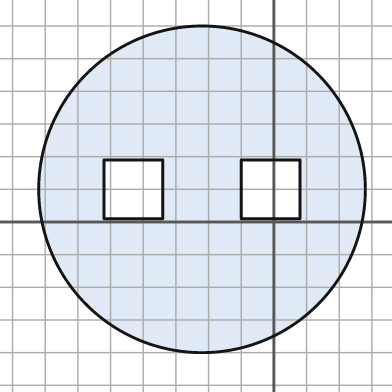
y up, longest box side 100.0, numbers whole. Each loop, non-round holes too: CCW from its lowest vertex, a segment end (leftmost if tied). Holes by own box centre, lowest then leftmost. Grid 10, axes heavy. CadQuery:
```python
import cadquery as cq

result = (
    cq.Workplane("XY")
    .moveTo(-22.0, 10.0)
    .circle(50.0)
    .moveTo(-52.0, 1.0)
    .lineTo(-34.0, 1.0)
    .lineTo(-34.0, 19.0)
    .lineTo(-52.0, 19.0)
    .close()
    .moveTo(-10.0, 1.0)
    .lineTo(8.0, 1.0)
    .lineTo(8.0, 19.0)
    .lineTo(-10.0, 19.0)
    .close()
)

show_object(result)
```